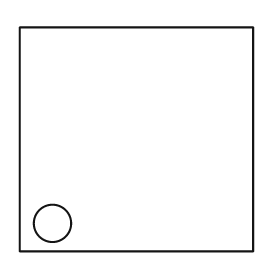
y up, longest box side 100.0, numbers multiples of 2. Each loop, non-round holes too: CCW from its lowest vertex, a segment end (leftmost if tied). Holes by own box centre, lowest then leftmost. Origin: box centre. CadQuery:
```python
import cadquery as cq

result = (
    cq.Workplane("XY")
    .moveTo(-50.0, -48.0)
    .lineTo(50.0, -48.0)
    .lineTo(50.0, 48.0)
    .lineTo(-50.0, 48.0)
    .close()
    .moveTo(-36.0, -36.0)
    .circle(8.0)
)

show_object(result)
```